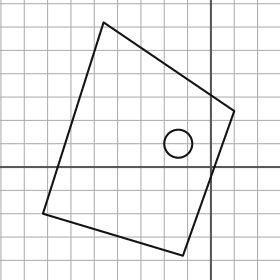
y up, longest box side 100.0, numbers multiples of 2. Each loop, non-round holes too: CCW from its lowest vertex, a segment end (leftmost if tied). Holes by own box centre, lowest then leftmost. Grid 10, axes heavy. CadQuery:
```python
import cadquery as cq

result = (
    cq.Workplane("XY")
    .moveTo(-12.0, -38.0)
    .lineTo(10.0, 24.0)
    .lineTo(-46.0, 62.0)
    .lineTo(-72.0, -20.0)
    .close()
    .moveTo(-14.0, 10.0)
    .circle(6.0)
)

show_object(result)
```